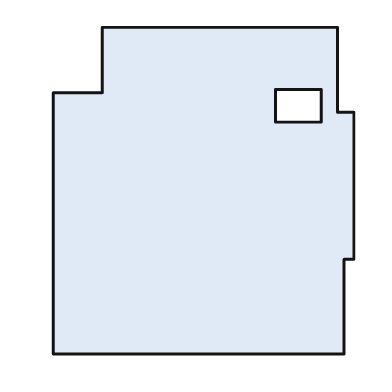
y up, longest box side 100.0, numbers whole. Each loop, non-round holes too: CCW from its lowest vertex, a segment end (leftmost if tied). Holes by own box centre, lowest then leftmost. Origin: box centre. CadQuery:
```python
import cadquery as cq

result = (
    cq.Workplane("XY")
    .moveTo(-46.0, -50.0)
    .lineTo(43.0, -50.0)
    .lineTo(43.0, -21.0)
    .lineTo(46.0, -21.0)
    .lineTo(46.0, 24.0)
    .lineTo(41.0, 24.0)
    .lineTo(41.0, 50.0)
    .lineTo(-31.0, 50.0)
    .lineTo(-31.0, 30.0)
    .lineTo(-46.0, 30.0)
    .close()
    .moveTo(22.0, 21.0)
    .lineTo(36.0, 21.0)
    .lineTo(36.0, 31.0)
    .lineTo(22.0, 31.0)
    .close()
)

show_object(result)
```